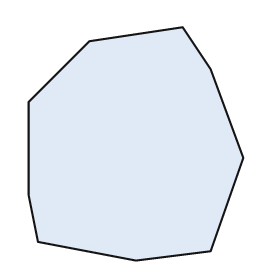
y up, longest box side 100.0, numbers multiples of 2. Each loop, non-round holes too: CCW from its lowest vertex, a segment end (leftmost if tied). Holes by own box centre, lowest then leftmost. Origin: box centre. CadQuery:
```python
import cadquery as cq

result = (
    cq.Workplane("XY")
    .moveTo(0.0, -50.0)
    .lineTo(32.0, -46.0)
    .lineTo(46.0, -6.0)
    .lineTo(32.0, 32.0)
    .lineTo(20.0, 50.0)
    .lineTo(-20.0, 44.0)
    .lineTo(-46.0, 18.0)
    .lineTo(-46.0, -22.0)
    .lineTo(-42.0, -42.0)
    .close()
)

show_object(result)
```